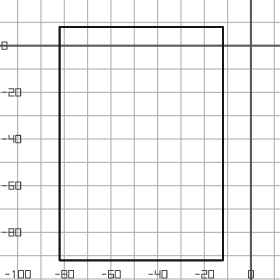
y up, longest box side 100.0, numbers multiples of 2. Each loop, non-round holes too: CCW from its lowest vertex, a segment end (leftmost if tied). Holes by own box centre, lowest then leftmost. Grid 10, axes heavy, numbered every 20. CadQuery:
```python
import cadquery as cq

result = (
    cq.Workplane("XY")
    .moveTo(-82.0, -92.0)
    .lineTo(-12.0, -92.0)
    .lineTo(-12.0, 8.0)
    .lineTo(-82.0, 8.0)
    .close()
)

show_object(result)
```